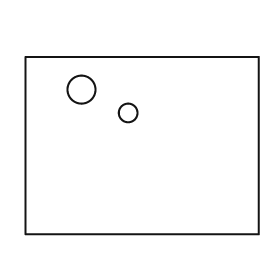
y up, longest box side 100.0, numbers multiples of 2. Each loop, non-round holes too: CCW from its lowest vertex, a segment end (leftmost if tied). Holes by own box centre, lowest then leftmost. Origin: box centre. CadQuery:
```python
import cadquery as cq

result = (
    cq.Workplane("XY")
    .moveTo(-50.0, -38.0)
    .lineTo(50.0, -38.0)
    .lineTo(50.0, 38.0)
    .lineTo(-50.0, 38.0)
    .close()
    .moveTo(-6.0, 14.0)
    .circle(4.0)
    .moveTo(-26.0, 24.0)
    .circle(6.0)
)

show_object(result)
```